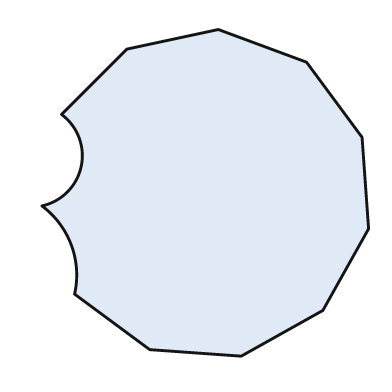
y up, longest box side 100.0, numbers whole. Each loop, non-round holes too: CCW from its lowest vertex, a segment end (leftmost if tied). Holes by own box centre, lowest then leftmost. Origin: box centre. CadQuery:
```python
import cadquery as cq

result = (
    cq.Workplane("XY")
    .moveTo(11.0, -50.0)
    .lineTo(36.0, -36.0)
    .lineTo(50.0, -11.0)
    .lineTo(48.0, 17.0)
    .lineTo(31.0, 40.0)
    .lineTo(4.0, 50.0)
    .lineTo(-24.0, 44.0)
    .lineTo(-44.0, 24.0)
    .threePointArc((-38.0, 8.0), (-50.0, -4.0))
    .threePointArc((-41.0, -16.0), (-40.0, -31.0))
    .lineTo(-17.0, -48.0)
    .close()
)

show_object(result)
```